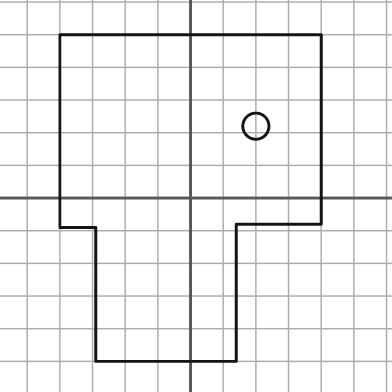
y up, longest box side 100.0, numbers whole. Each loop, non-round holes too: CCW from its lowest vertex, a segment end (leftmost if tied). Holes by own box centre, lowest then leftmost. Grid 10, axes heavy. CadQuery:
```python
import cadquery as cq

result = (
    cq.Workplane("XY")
    .moveTo(-29.0, -50.0)
    .lineTo(14.0, -50.0)
    .lineTo(14.0, -8.0)
    .lineTo(40.0, -8.0)
    .lineTo(40.0, 50.0)
    .lineTo(-40.0, 50.0)
    .lineTo(-40.0, -9.0)
    .lineTo(-29.0, -9.0)
    .close()
    .moveTo(20.0, 22.0)
    .circle(4.0)
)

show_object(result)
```